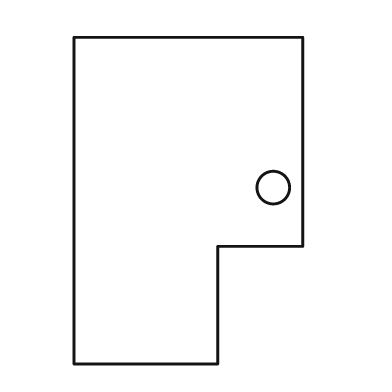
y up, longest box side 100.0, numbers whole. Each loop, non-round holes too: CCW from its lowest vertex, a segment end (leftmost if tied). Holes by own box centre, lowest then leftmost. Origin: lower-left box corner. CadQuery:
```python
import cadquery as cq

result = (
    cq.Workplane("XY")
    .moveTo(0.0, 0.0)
    .lineTo(44.0, 0.0)
    .lineTo(44.0, 36.0)
    .lineTo(70.0, 36.0)
    .lineTo(70.0, 100.0)
    .lineTo(0.0, 100.0)
    .close()
    .moveTo(61.0, 54.0)
    .circle(5.0)
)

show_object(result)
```